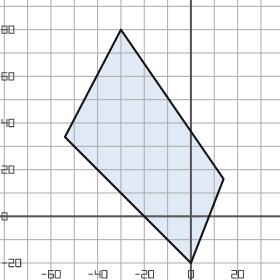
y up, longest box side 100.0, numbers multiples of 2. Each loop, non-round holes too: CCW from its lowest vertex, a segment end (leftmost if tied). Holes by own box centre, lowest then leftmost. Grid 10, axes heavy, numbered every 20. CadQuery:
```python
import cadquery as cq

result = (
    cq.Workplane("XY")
    .moveTo(0.0, -20.0)
    .lineTo(14.0, 16.0)
    .lineTo(-30.0, 80.0)
    .lineTo(-54.0, 34.0)
    .close()
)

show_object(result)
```